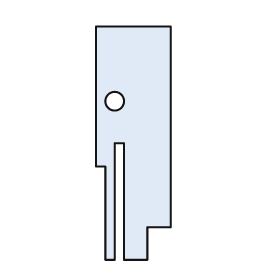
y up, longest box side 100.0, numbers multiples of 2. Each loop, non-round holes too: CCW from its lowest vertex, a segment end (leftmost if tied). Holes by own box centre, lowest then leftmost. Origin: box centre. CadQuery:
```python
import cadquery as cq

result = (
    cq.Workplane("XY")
    .moveTo(-12.0, -50.0)
    .lineTo(-8.0, -50.0)
    .lineTo(-8.0, 0.0)
    .lineTo(-4.0, 0.0)
    .lineTo(-4.0, -50.0)
    .lineTo(6.0, -50.0)
    .lineTo(6.0, -36.0)
    .lineTo(16.0, -36.0)
    .lineTo(16.0, 50.0)
    .lineTo(-16.0, 50.0)
    .lineTo(-16.0, -10.0)
    .lineTo(-12.0, -10.0)
    .close()
    .moveTo(-8.0, 18.0)
    .circle(4.0)
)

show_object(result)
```